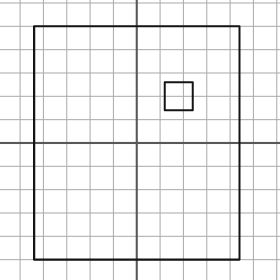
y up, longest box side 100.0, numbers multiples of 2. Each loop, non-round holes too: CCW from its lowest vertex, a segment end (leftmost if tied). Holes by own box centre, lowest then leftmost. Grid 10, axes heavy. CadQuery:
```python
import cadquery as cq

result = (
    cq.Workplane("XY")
    .moveTo(-44.0, -50.0)
    .lineTo(44.0, -50.0)
    .lineTo(44.0, 50.0)
    .lineTo(-44.0, 50.0)
    .close()
    .moveTo(12.0, 14.0)
    .lineTo(24.0, 14.0)
    .lineTo(24.0, 26.0)
    .lineTo(12.0, 26.0)
    .close()
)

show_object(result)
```